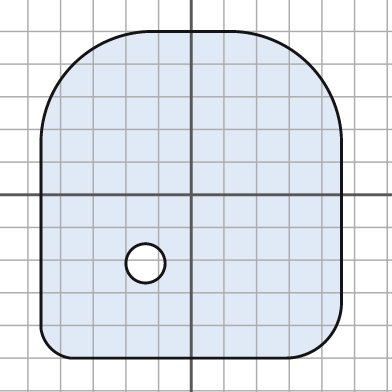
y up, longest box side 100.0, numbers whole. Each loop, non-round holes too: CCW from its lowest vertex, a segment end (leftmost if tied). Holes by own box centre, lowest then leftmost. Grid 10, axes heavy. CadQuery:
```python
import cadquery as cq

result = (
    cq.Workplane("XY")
    .moveTo(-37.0, -50.0)
    .lineTo(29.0, -50.0)
    .threePointArc((41.0, -45.0), (46.0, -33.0))
    .lineTo(46.0, 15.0)
    .threePointArc((36.0, 40.0), (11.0, 50.0))
    .lineTo(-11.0, 50.0)
    .threePointArc((-36.0, 40.0), (-46.0, 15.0))
    .lineTo(-46.0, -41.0)
    .threePointArc((-43.0, -47.0), (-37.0, -50.0))
    .close()
    .moveTo(-14.0, -21.0)
    .circle(6.0)
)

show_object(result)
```